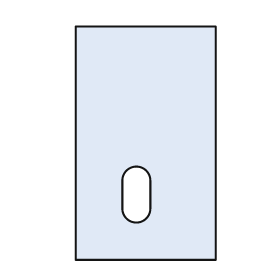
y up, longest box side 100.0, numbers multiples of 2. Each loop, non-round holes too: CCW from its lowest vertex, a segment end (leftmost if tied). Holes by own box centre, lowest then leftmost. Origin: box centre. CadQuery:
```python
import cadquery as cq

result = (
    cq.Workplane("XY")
    .moveTo(-30.0, -50.0)
    .lineTo(30.0, -50.0)
    .lineTo(30.0, 50.0)
    .lineTo(-30.0, 50.0)
    .close()
    .moveTo(-10.0, -28.0)
    .threePointArc((-4.0, -34.0), (2.0, -28.0))
    .lineTo(2.0, -16.0)
    .threePointArc((-4.0, -10.0), (-10.0, -16.0))
    .close()
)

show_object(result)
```